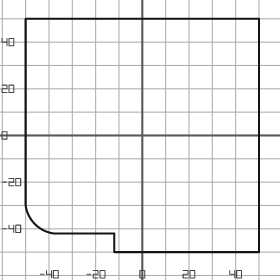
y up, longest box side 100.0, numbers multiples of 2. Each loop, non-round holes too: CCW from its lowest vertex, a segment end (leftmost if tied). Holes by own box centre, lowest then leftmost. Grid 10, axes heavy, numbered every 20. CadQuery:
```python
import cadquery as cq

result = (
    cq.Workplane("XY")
    .moveTo(-12.0, -50.0)
    .lineTo(50.0, -50.0)
    .lineTo(50.0, 50.0)
    .lineTo(-50.0, 50.0)
    .lineTo(-50.0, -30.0)
    .threePointArc((-46.0, -38.0), (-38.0, -42.0))
    .lineTo(-12.0, -42.0)
    .close()
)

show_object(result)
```